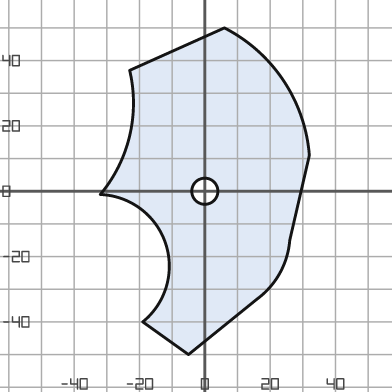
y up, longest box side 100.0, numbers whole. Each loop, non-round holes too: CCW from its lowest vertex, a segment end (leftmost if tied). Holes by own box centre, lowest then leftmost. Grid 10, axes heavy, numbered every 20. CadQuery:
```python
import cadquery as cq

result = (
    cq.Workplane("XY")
    .moveTo(-5.0, -50.0)
    .lineTo(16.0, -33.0)
    .threePointArc((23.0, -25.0), (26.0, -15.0))
    .lineTo(32.0, 11.0)
    .threePointArc((24.0, 34.0), (6.0, 50.0))
    .lineTo(-23.0, 37.0)
    .threePointArc((-23.0, 17.0), (-32.0, -1.0))
    .threePointArc((-12.0, -16.0), (-19.0, -40.0))
    .close()
    .moveTo(0.0, 0.0)
    .circle(4.0)
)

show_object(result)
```